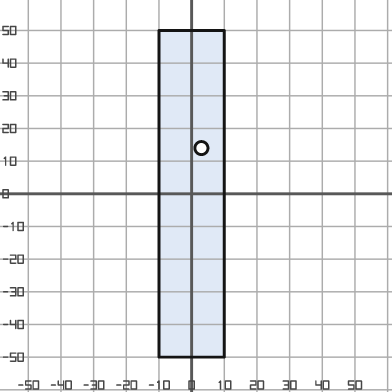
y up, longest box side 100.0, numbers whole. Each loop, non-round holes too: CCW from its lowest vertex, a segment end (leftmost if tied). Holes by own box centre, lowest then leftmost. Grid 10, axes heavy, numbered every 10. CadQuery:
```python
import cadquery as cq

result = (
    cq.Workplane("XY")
    .moveTo(-10.0, -50.0)
    .lineTo(10.0, -50.0)
    .lineTo(10.0, 50.0)
    .lineTo(-10.0, 50.0)
    .close()
    .moveTo(3.0, 14.0)
    .circle(2.0)
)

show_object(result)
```